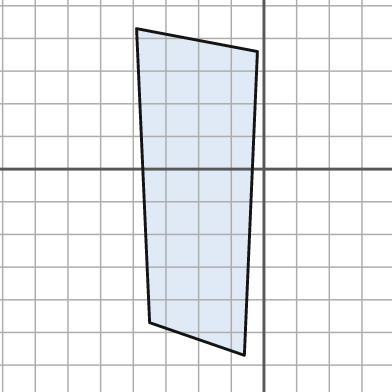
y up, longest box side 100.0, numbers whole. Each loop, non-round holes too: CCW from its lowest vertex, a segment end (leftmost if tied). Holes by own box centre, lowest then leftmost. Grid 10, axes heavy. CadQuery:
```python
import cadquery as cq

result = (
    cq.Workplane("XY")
    .moveTo(-6.0, -57.0)
    .lineTo(-2.0, 36.0)
    .lineTo(-39.0, 43.0)
    .lineTo(-35.0, -47.0)
    .close()
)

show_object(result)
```